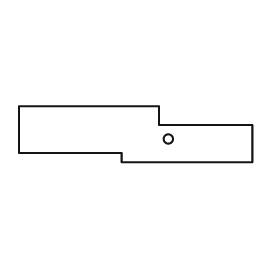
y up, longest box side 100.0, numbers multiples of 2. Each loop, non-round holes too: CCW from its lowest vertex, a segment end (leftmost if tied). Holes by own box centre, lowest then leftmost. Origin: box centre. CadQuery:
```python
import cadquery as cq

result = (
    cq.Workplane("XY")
    .moveTo(-6.0, -12.0)
    .lineTo(50.0, -12.0)
    .lineTo(50.0, 4.0)
    .lineTo(10.0, 4.0)
    .lineTo(10.0, 12.0)
    .lineTo(-50.0, 12.0)
    .lineTo(-50.0, -8.0)
    .lineTo(-6.0, -8.0)
    .close()
    .moveTo(14.0, -2.0)
    .circle(2.0)
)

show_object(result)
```